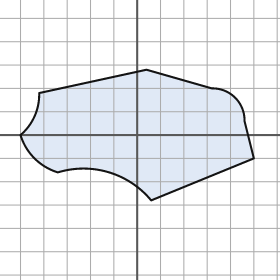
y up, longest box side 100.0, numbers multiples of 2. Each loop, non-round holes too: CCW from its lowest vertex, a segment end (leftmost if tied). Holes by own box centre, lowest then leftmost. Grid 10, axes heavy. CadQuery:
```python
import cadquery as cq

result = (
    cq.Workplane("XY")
    .moveTo(6.0, -28.0)
    .lineTo(50.0, -10.0)
    .lineTo(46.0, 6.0)
    .threePointArc((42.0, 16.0), (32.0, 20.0))
    .lineTo(4.0, 28.0)
    .lineTo(-42.0, 18.0)
    .threePointArc((-44.0, 8.0), (-50.0, 0.0))
    .threePointArc((-44.0, -10.0), (-34.0, -16.0))
    .threePointArc((-12.0, -16.0), (6.0, -28.0))
    .close()
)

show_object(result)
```